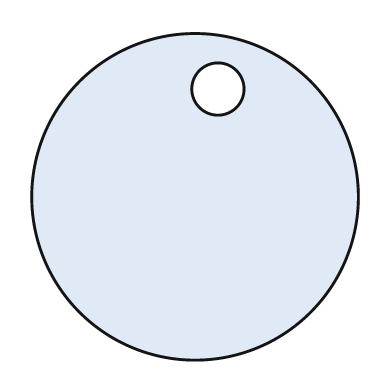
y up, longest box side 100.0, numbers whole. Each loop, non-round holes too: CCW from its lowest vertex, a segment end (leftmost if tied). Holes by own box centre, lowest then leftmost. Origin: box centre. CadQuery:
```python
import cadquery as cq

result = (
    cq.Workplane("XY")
    .moveTo(0.0, 0.0)
    .circle(50.0)
    .moveTo(7.0, 33.0)
    .circle(8.0)
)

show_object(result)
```